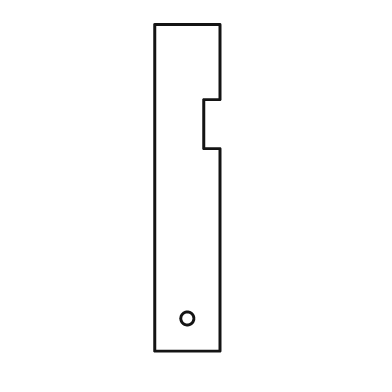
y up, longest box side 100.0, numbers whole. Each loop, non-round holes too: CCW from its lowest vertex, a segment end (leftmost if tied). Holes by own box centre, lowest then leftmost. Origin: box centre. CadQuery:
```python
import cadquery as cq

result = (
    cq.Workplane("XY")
    .moveTo(-10.0, -50.0)
    .lineTo(10.0, -50.0)
    .lineTo(10.0, 12.0)
    .lineTo(5.0, 12.0)
    .lineTo(5.0, 27.0)
    .lineTo(10.0, 27.0)
    .lineTo(10.0, 50.0)
    .lineTo(-10.0, 50.0)
    .close()
    .moveTo(0.0, -40.0)
    .circle(2.0)
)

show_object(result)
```